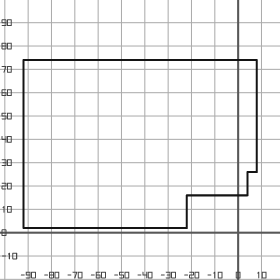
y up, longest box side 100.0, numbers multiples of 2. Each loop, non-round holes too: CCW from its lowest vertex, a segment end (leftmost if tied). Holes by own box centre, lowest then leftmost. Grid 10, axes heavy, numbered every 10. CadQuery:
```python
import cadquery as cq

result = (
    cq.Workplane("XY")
    .moveTo(-92.0, 2.0)
    .lineTo(-22.0, 2.0)
    .lineTo(-22.0, 16.0)
    .lineTo(4.0, 16.0)
    .lineTo(4.0, 26.0)
    .lineTo(8.0, 26.0)
    .lineTo(8.0, 74.0)
    .lineTo(-92.0, 74.0)
    .close()
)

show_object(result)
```